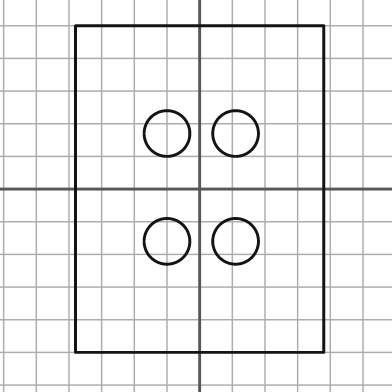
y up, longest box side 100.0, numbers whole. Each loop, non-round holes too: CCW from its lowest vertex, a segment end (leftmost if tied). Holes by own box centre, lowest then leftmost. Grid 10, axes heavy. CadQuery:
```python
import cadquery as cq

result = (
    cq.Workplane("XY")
    .moveTo(-38.0, -50.0)
    .lineTo(38.0, -50.0)
    .lineTo(38.0, 50.0)
    .lineTo(-38.0, 50.0)
    .close()
    .moveTo(-10.0, -16.0)
    .circle(7.0)
    .moveTo(11.0, -16.0)
    .circle(7.0)
    .moveTo(-10.0, 17.0)
    .circle(7.0)
    .moveTo(11.0, 17.0)
    .circle(7.0)
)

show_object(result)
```